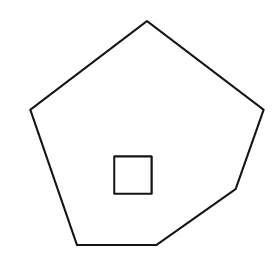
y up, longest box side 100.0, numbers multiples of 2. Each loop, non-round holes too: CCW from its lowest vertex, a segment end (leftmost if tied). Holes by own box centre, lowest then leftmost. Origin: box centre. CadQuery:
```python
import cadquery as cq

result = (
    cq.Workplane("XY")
    .moveTo(-30.0, -48.0)
    .lineTo(4.0, -48.0)
    .lineTo(38.0, -24.0)
    .lineTo(50.0, 10.0)
    .lineTo(0.0, 48.0)
    .lineTo(-50.0, 10.0)
    .close()
    .moveTo(-14.0, -26.0)
    .lineTo(2.0, -26.0)
    .lineTo(2.0, -10.0)
    .lineTo(-14.0, -10.0)
    .close()
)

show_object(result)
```